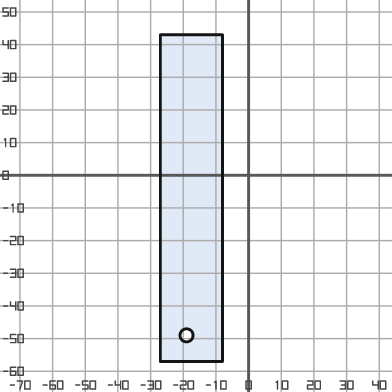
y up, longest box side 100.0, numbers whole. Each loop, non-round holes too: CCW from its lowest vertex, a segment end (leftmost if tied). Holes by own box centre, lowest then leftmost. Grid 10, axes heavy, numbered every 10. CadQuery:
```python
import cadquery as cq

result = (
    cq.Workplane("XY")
    .moveTo(-27.0, -57.0)
    .lineTo(-8.0, -57.0)
    .lineTo(-8.0, 43.0)
    .lineTo(-27.0, 43.0)
    .close()
    .moveTo(-19.0, -49.0)
    .circle(2.0)
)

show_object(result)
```